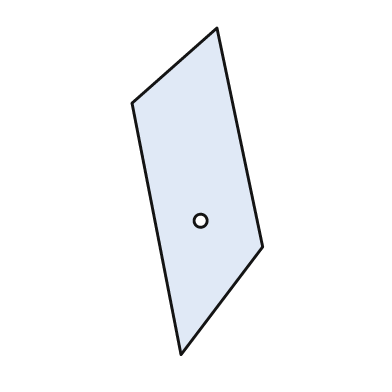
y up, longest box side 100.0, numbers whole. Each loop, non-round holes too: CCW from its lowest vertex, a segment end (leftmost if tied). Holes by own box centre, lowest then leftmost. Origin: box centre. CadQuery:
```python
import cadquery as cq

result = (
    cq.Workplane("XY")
    .moveTo(-5.0, -50.0)
    .lineTo(20.0, -17.0)
    .lineTo(6.0, 50.0)
    .lineTo(-20.0, 27.0)
    .close()
    .moveTo(1.0, -9.0)
    .circle(2.0)
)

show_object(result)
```